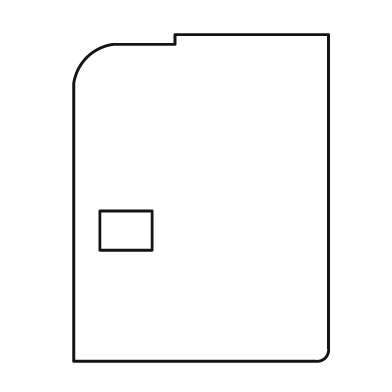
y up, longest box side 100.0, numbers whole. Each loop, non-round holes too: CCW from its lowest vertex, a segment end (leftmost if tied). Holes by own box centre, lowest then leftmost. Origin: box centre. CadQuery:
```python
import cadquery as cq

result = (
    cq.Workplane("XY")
    .moveTo(-39.0, -50.0)
    .lineTo(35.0, -50.0)
    .threePointArc((38.0, -49.0), (39.0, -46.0))
    .lineTo(39.0, 50.0)
    .lineTo(-8.0, 50.0)
    .lineTo(-8.0, 47.0)
    .lineTo(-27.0, 47.0)
    .threePointArc((-35.0, 43.0), (-39.0, 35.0))
    .close()
    .moveTo(-31.0, -16.0)
    .lineTo(-15.0, -16.0)
    .lineTo(-15.0, -4.0)
    .lineTo(-31.0, -4.0)
    .close()
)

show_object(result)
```